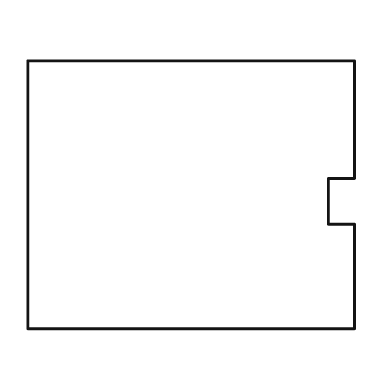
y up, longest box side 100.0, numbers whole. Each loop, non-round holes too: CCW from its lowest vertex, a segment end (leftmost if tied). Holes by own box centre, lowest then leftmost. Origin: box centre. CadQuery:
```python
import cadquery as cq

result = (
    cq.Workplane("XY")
    .moveTo(-50.0, -41.0)
    .lineTo(50.0, -41.0)
    .lineTo(50.0, -9.0)
    .lineTo(42.0, -9.0)
    .lineTo(42.0, 5.0)
    .lineTo(50.0, 5.0)
    .lineTo(50.0, 41.0)
    .lineTo(-50.0, 41.0)
    .close()
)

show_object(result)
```